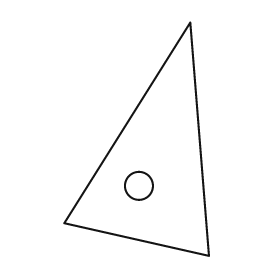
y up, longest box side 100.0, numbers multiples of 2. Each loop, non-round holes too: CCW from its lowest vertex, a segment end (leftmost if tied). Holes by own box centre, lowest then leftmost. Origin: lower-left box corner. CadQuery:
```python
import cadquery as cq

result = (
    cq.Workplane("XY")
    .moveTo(62.0, 0.0)
    .lineTo(54.0, 100.0)
    .lineTo(0.0, 14.0)
    .close()
    .moveTo(32.0, 30.0)
    .circle(6.0)
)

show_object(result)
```